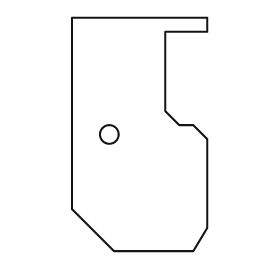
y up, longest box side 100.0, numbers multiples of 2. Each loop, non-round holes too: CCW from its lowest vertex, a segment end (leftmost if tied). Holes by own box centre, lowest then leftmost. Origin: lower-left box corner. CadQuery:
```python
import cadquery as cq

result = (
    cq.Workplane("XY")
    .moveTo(18.0, 0.0)
    .lineTo(52.0, 0.0)
    .lineTo(58.0, 10.0)
    .lineTo(58.0, 48.0)
    .lineTo(52.0, 54.0)
    .lineTo(46.0, 54.0)
    .lineTo(40.0, 60.0)
    .lineTo(40.0, 94.0)
    .lineTo(58.0, 94.0)
    .lineTo(58.0, 100.0)
    .lineTo(0.0, 100.0)
    .lineTo(0.0, 18.0)
    .close()
    .moveTo(16.0, 50.0)
    .circle(4.0)
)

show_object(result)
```